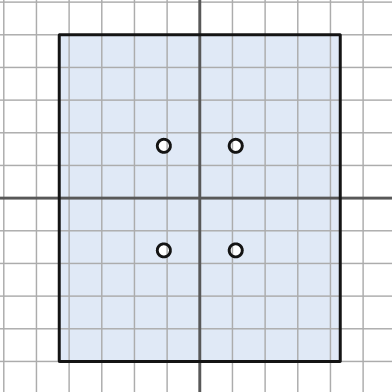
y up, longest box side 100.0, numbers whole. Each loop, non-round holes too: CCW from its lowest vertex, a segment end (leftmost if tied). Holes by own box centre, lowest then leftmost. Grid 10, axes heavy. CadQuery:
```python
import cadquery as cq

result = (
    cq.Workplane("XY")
    .moveTo(-43.0, -50.0)
    .lineTo(43.0, -50.0)
    .lineTo(43.0, 50.0)
    .lineTo(-43.0, 50.0)
    .close()
    .moveTo(-11.0, -16.0)
    .circle(2.0)
    .moveTo(11.0, -16.0)
    .circle(2.0)
    .moveTo(-11.0, 16.0)
    .circle(2.0)
    .moveTo(11.0, 16.0)
    .circle(2.0)
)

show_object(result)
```